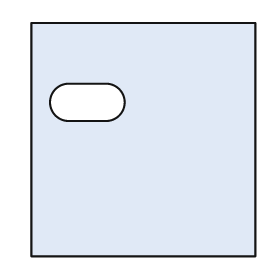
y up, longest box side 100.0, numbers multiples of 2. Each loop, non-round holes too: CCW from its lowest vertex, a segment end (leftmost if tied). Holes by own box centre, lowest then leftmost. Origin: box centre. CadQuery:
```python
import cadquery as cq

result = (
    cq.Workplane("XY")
    .moveTo(-48.0, -50.0)
    .lineTo(48.0, -50.0)
    .lineTo(48.0, 50.0)
    .lineTo(-48.0, 50.0)
    .close()
    .moveTo(-32.0, 8.0)
    .lineTo(-16.0, 8.0)
    .threePointArc((-8.0, 16.0), (-16.0, 24.0))
    .lineTo(-32.0, 24.0)
    .threePointArc((-40.0, 16.0), (-32.0, 8.0))
    .close()
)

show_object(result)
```